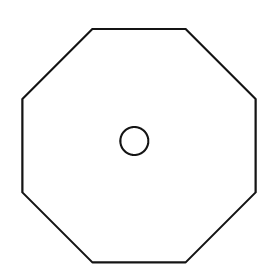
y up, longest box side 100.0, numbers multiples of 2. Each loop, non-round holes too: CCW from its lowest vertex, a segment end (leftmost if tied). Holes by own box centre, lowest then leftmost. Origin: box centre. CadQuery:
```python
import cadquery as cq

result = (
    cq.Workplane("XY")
    .moveTo(-20.0, -50.0)
    .lineTo(20.0, -50.0)
    .lineTo(50.0, -20.0)
    .lineTo(50.0, 20.0)
    .lineTo(20.0, 50.0)
    .lineTo(-20.0, 50.0)
    .lineTo(-50.0, 20.0)
    .lineTo(-50.0, -20.0)
    .close()
    .moveTo(-2.0, 2.0)
    .circle(6.0)
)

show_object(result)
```